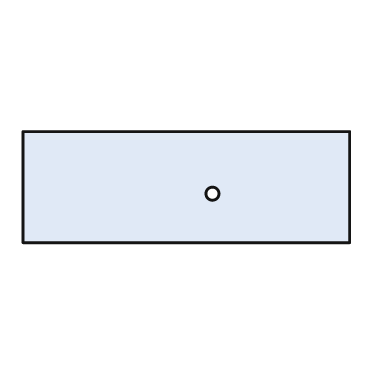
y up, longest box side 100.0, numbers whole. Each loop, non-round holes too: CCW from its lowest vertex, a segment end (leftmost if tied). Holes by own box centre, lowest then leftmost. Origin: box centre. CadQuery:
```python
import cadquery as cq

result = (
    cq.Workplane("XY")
    .moveTo(-50.0, -17.0)
    .lineTo(50.0, -17.0)
    .lineTo(50.0, 17.0)
    .lineTo(-50.0, 17.0)
    .close()
    .moveTo(8.0, -2.0)
    .circle(2.0)
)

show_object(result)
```